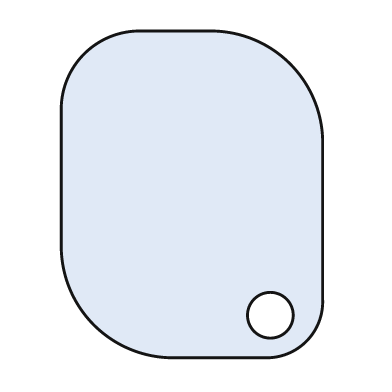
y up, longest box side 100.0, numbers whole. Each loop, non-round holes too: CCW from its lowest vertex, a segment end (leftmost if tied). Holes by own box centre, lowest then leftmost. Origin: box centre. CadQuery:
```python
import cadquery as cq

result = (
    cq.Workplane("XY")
    .moveTo(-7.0, -50.0)
    .lineTo(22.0, -50.0)
    .threePointArc((35.0, -45.0), (40.0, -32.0))
    .lineTo(40.0, 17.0)
    .threePointArc((30.0, 40.0), (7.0, 50.0))
    .lineTo(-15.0, 50.0)
    .threePointArc((-33.0, 43.0), (-40.0, 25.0))
    .lineTo(-40.0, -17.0)
    .threePointArc((-30.0, -40.0), (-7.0, -50.0))
    .close()
    .moveTo(24.0, -37.0)
    .circle(7.0)
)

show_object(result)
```